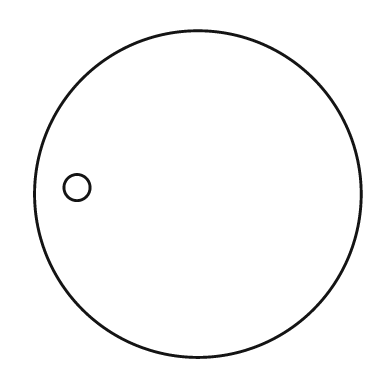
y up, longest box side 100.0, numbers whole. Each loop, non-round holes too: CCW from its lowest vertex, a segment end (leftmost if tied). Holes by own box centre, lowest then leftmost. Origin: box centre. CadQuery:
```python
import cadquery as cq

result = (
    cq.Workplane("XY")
    .moveTo(0.0, 0.0)
    .circle(50.0)
    .moveTo(-37.0, 2.0)
    .circle(4.0)
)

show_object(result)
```